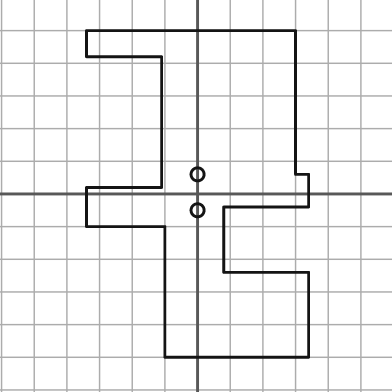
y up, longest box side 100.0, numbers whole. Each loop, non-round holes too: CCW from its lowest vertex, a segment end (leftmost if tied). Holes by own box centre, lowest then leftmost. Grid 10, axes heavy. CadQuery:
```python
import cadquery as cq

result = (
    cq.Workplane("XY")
    .moveTo(-10.0, -50.0)
    .lineTo(34.0, -50.0)
    .lineTo(34.0, -24.0)
    .lineTo(8.0, -24.0)
    .lineTo(8.0, -4.0)
    .lineTo(34.0, -4.0)
    .lineTo(34.0, 6.0)
    .lineTo(30.0, 6.0)
    .lineTo(30.0, 50.0)
    .lineTo(-34.0, 50.0)
    .lineTo(-34.0, 42.0)
    .lineTo(-11.0, 42.0)
    .lineTo(-11.0, 2.0)
    .lineTo(-34.0, 2.0)
    .lineTo(-34.0, -10.0)
    .lineTo(-10.0, -10.0)
    .close()
    .moveTo(0.0, -5.0)
    .circle(2.0)
    .moveTo(0.0, 6.0)
    .circle(2.0)
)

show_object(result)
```